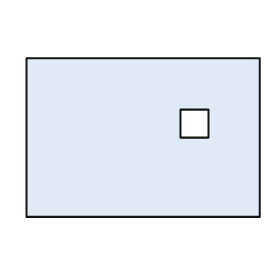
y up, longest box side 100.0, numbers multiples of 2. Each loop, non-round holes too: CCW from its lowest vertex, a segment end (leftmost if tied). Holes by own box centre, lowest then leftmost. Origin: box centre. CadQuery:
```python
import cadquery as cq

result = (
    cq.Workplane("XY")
    .moveTo(-50.0, -34.0)
    .lineTo(50.0, -34.0)
    .lineTo(50.0, 34.0)
    .lineTo(-50.0, 34.0)
    .close()
    .moveTo(16.0, 0.0)
    .lineTo(28.0, 0.0)
    .lineTo(28.0, 12.0)
    .lineTo(16.0, 12.0)
    .close()
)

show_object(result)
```